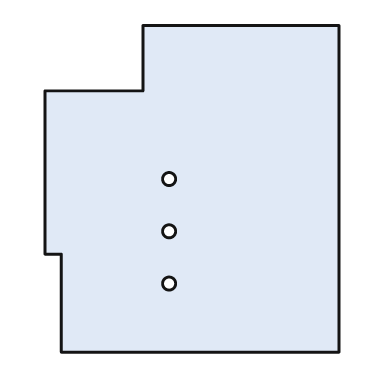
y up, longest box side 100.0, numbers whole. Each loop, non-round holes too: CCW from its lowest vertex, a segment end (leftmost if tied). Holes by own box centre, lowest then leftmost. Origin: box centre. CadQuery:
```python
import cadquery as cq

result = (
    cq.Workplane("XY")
    .moveTo(-40.0, -50.0)
    .lineTo(45.0, -50.0)
    .lineTo(45.0, 50.0)
    .lineTo(-15.0, 50.0)
    .lineTo(-15.0, 30.0)
    .lineTo(-45.0, 30.0)
    .lineTo(-45.0, -20.0)
    .lineTo(-40.0, -20.0)
    .close()
    .moveTo(-7.0, -29.0)
    .circle(2.0)
    .moveTo(-7.0, -13.0)
    .circle(2.0)
    .moveTo(-7.0, 3.0)
    .circle(2.0)
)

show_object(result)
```